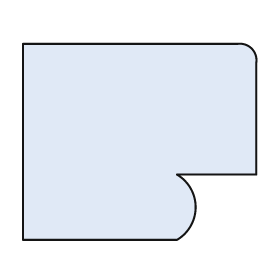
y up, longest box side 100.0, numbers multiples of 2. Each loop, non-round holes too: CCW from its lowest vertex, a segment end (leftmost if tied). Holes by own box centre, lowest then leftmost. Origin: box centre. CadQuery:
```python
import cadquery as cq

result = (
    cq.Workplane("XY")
    .moveTo(-50.0, -42.0)
    .lineTo(16.0, -42.0)
    .threePointArc((24.0, -28.0), (16.0, -14.0))
    .lineTo(50.0, -14.0)
    .lineTo(50.0, 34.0)
    .threePointArc((48.0, 40.0), (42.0, 42.0))
    .lineTo(-50.0, 42.0)
    .close()
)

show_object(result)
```